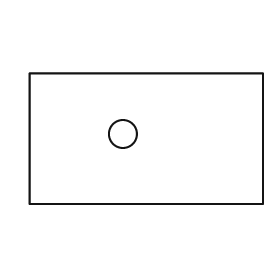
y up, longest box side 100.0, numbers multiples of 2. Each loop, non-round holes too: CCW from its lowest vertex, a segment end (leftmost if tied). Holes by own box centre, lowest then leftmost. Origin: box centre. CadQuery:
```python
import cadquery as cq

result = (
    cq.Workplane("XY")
    .moveTo(-50.0, -28.0)
    .lineTo(50.0, -28.0)
    .lineTo(50.0, 28.0)
    .lineTo(-50.0, 28.0)
    .close()
    .moveTo(-10.0, 2.0)
    .circle(6.0)
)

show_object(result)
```